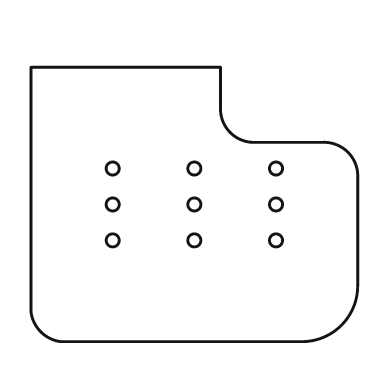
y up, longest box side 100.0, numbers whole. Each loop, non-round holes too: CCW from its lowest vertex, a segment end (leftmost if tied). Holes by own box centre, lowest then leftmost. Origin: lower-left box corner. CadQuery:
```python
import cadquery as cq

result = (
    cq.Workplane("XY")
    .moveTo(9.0, 0.0)
    .lineTo(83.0, 0.0)
    .threePointArc((95.0, 5.0), (100.0, 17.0))
    .lineTo(100.0, 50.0)
    .threePointArc((97.0, 58.0), (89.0, 61.0))
    .lineTo(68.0, 61.0)
    .threePointArc((61.0, 64.0), (58.0, 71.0))
    .lineTo(58.0, 84.0)
    .lineTo(0.0, 84.0)
    .lineTo(0.0, 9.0)
    .threePointArc((3.0, 3.0), (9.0, 0.0))
    .close()
    .moveTo(25.0, 31.0)
    .circle(2.0)
    .moveTo(50.0, 31.0)
    .circle(2.0)
    .moveTo(75.0, 31.0)
    .circle(2.0)
    .moveTo(25.0, 42.0)
    .circle(2.0)
    .moveTo(50.0, 42.0)
    .circle(2.0)
    .moveTo(75.0, 42.0)
    .circle(2.0)
    .moveTo(25.0, 53.0)
    .circle(2.0)
    .moveTo(50.0, 53.0)
    .circle(2.0)
    .moveTo(75.0, 53.0)
    .circle(2.0)
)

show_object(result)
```